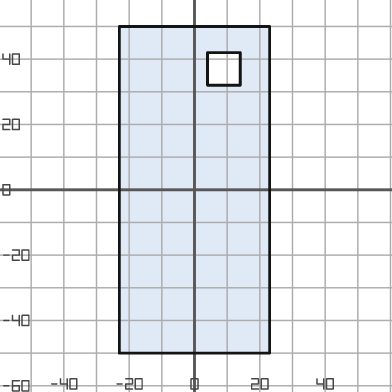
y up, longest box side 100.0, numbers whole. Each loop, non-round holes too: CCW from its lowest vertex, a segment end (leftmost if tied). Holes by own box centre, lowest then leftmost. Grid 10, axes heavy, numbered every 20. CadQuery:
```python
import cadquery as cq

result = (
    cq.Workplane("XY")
    .moveTo(-23.0, -50.0)
    .lineTo(23.0, -50.0)
    .lineTo(23.0, 50.0)
    .lineTo(-23.0, 50.0)
    .close()
    .moveTo(4.0, 32.0)
    .lineTo(14.0, 32.0)
    .lineTo(14.0, 42.0)
    .lineTo(4.0, 42.0)
    .close()
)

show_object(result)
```